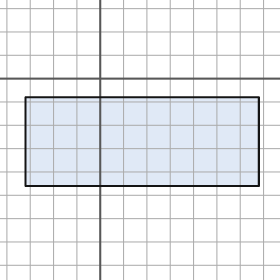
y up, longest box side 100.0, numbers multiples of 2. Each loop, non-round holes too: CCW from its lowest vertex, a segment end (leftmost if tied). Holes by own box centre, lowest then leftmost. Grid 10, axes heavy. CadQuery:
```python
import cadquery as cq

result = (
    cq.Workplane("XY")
    .moveTo(-32.0, -46.0)
    .lineTo(68.0, -46.0)
    .lineTo(68.0, -8.0)
    .lineTo(-32.0, -8.0)
    .close()
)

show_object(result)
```